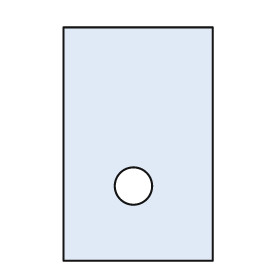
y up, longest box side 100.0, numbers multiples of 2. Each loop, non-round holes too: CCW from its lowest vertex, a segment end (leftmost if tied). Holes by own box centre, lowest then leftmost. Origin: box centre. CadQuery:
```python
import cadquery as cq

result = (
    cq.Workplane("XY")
    .moveTo(-32.0, -50.0)
    .lineTo(32.0, -50.0)
    .lineTo(32.0, 50.0)
    .lineTo(-32.0, 50.0)
    .close()
    .moveTo(-2.0, -18.0)
    .circle(8.0)
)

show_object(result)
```